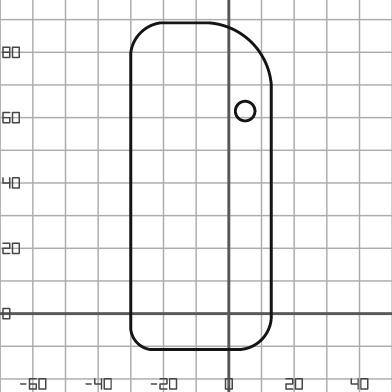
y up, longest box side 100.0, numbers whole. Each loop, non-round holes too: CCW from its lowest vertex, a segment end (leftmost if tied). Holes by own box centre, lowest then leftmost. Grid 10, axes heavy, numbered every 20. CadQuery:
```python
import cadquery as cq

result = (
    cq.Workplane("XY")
    .moveTo(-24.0, -11.0)
    .lineTo(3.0, -11.0)
    .threePointArc((10.0, -8.0), (13.0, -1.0))
    .lineTo(13.0, 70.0)
    .threePointArc((7.0, 83.0), (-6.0, 89.0))
    .lineTo(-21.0, 89.0)
    .threePointArc((-27.0, 86.0), (-30.0, 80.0))
    .lineTo(-30.0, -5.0)
    .threePointArc((-28.0, -9.0), (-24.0, -11.0))
    .close()
    .moveTo(5.0, 62.0)
    .circle(3.0)
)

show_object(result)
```